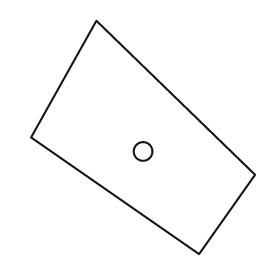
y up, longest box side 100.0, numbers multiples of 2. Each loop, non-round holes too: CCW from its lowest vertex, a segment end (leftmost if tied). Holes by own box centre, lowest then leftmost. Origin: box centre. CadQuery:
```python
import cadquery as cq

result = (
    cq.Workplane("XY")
    .moveTo(24.0, -50.0)
    .lineTo(48.0, -16.0)
    .lineTo(-20.0, 50.0)
    .lineTo(-48.0, 0.0)
    .close()
    .moveTo(0.0, -6.0)
    .circle(4.0)
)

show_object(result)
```